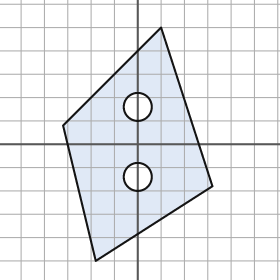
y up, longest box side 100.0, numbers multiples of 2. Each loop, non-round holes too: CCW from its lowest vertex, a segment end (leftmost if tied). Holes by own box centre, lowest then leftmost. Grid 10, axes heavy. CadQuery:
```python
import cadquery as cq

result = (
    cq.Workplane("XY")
    .moveTo(-18.0, -50.0)
    .lineTo(32.0, -18.0)
    .lineTo(10.0, 50.0)
    .lineTo(-32.0, 8.0)
    .close()
    .moveTo(0.0, -14.0)
    .circle(6.0)
    .moveTo(0.0, 16.0)
    .circle(6.0)
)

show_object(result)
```